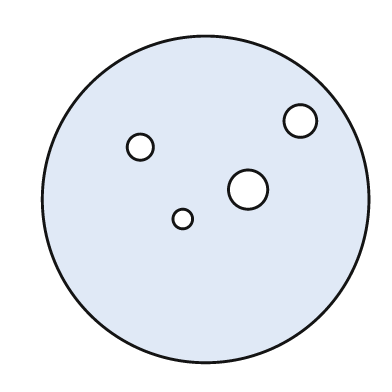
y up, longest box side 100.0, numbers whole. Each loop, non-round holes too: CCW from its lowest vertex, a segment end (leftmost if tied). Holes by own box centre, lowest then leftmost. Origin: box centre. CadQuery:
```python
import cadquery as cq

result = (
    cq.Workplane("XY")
    .moveTo(0.0, 0.0)
    .circle(50.0)
    .moveTo(-7.0, -6.0)
    .circle(3.0)
    .moveTo(13.0, 3.0)
    .circle(6.0)
    .moveTo(-20.0, 16.0)
    .circle(4.0)
    .moveTo(29.0, 24.0)
    .circle(5.0)
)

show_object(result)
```